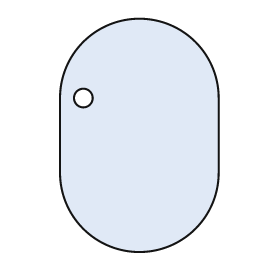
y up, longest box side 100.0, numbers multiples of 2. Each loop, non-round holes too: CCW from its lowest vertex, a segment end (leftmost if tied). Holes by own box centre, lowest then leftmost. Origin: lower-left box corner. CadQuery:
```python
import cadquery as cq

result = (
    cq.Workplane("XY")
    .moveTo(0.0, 34.0)
    .threePointArc((34.0, 0.0), (68.0, 34.0))
    .lineTo(68.0, 66.0)
    .threePointArc((34.0, 100.0), (0.0, 66.0))
    .close()
    .moveTo(10.0, 66.0)
    .circle(4.0)
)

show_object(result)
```